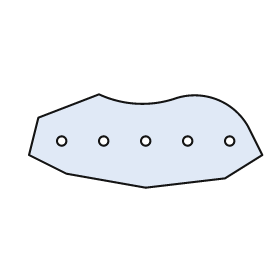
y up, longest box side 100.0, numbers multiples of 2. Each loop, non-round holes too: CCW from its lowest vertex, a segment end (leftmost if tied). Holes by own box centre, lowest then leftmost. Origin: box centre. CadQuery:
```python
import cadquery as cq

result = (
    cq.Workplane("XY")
    .moveTo(0.0, -20.0)
    .lineTo(34.0, -16.0)
    .lineTo(50.0, -6.0)
    .lineTo(44.0, 6.0)
    .threePointArc((30.0, 18.0), (12.0, 18.0))
    .threePointArc((-4.0, 16.0), (-20.0, 20.0))
    .lineTo(-46.0, 10.0)
    .lineTo(-50.0, -6.0)
    .lineTo(-34.0, -14.0)
    .close()
    .moveTo(-36.0, 0.0)
    .circle(2.0)
    .moveTo(-18.0, 0.0)
    .circle(2.0)
    .moveTo(0.0, 0.0)
    .circle(2.0)
    .moveTo(18.0, 0.0)
    .circle(2.0)
    .moveTo(36.0, 0.0)
    .circle(2.0)
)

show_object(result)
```